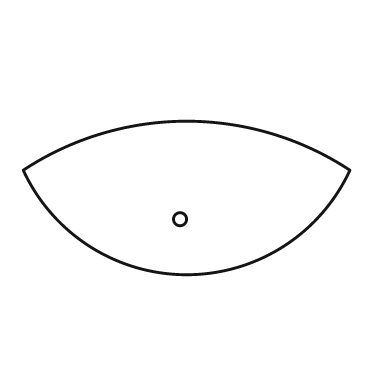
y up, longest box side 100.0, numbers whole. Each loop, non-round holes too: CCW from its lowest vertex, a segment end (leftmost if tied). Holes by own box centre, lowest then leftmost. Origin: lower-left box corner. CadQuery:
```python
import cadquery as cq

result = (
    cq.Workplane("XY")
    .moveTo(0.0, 32.0)
    .threePointArc((50.0, 0.0), (100.0, 32.0))
    .threePointArc((50.0, 47.0), (0.0, 32.0))
    .close()
    .moveTo(48.0, 17.0)
    .circle(2.0)
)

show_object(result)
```